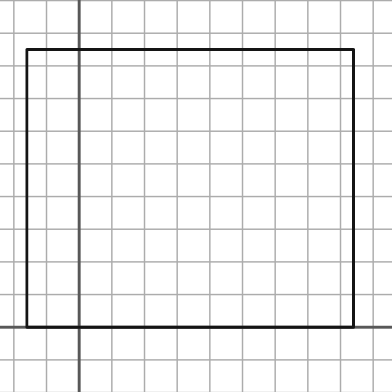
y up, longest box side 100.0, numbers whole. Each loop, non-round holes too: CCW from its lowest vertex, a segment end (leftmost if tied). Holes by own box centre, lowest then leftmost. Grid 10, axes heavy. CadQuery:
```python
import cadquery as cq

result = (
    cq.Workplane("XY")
    .moveTo(-16.0, 0.0)
    .lineTo(84.0, 0.0)
    .lineTo(84.0, 85.0)
    .lineTo(-16.0, 85.0)
    .close()
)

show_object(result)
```